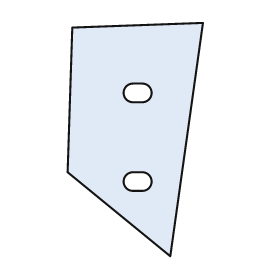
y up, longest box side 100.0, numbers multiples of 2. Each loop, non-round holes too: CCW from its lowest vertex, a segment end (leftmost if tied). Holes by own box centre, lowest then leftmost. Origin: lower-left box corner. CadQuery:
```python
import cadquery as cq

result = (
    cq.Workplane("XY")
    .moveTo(44.0, 0.0)
    .lineTo(58.0, 100.0)
    .lineTo(2.0, 98.0)
    .lineTo(0.0, 36.0)
    .close()
    .moveTo(28.0, 28.0)
    .lineTo(32.0, 28.0)
    .threePointArc((36.0, 32.0), (32.0, 36.0))
    .lineTo(28.0, 36.0)
    .threePointArc((24.0, 32.0), (28.0, 28.0))
    .close()
    .moveTo(28.0, 66.0)
    .lineTo(32.0, 66.0)
    .threePointArc((36.0, 70.0), (32.0, 74.0))
    .lineTo(28.0, 74.0)
    .threePointArc((24.0, 70.0), (28.0, 66.0))
    .close()
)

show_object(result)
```